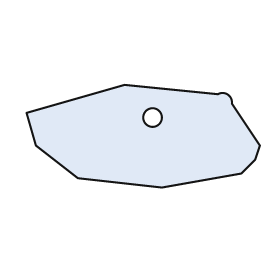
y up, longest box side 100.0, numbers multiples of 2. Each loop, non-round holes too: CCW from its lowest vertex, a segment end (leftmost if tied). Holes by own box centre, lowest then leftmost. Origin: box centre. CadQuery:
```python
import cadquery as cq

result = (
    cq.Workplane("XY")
    .moveTo(8.0, -22.0)
    .lineTo(42.0, -16.0)
    .lineTo(48.0, -10.0)
    .lineTo(50.0, -4.0)
    .lineTo(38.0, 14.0)
    .threePointArc((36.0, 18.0), (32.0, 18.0))
    .lineTo(-8.0, 22.0)
    .lineTo(-50.0, 10.0)
    .lineTo(-46.0, -4.0)
    .lineTo(-28.0, -18.0)
    .close()
    .moveTo(4.0, 8.0)
    .circle(4.0)
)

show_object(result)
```